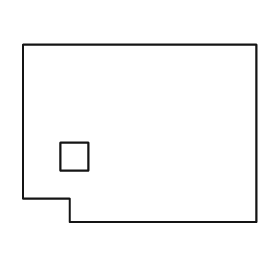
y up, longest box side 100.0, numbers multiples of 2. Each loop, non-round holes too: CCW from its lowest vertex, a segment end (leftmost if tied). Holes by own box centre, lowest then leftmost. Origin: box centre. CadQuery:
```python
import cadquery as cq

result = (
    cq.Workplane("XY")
    .moveTo(-30.0, -38.0)
    .lineTo(50.0, -38.0)
    .lineTo(50.0, 38.0)
    .lineTo(-50.0, 38.0)
    .lineTo(-50.0, -28.0)
    .lineTo(-30.0, -28.0)
    .close()
    .moveTo(-34.0, -16.0)
    .lineTo(-22.0, -16.0)
    .lineTo(-22.0, -4.0)
    .lineTo(-34.0, -4.0)
    .close()
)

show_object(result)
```